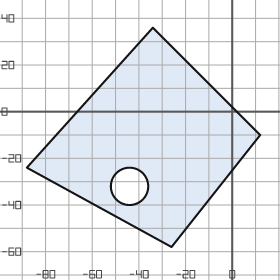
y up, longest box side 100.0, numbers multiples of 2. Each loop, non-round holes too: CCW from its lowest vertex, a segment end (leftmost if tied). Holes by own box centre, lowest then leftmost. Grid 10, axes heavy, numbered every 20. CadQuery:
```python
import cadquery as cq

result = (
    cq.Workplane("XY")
    .moveTo(-26.0, -58.0)
    .lineTo(12.0, -10.0)
    .lineTo(-34.0, 36.0)
    .lineTo(-88.0, -24.0)
    .close()
    .moveTo(-44.0, -32.0)
    .circle(8.0)
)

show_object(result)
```